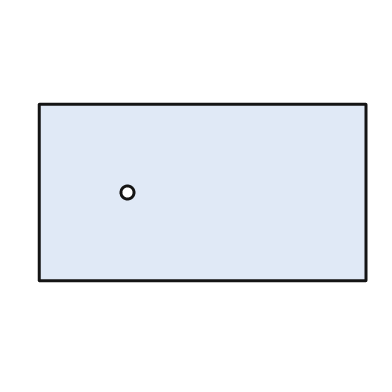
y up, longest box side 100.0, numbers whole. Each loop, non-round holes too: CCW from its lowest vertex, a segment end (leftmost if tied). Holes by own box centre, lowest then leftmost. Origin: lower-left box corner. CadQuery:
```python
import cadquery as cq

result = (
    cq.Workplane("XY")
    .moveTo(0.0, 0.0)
    .lineTo(100.0, 0.0)
    .lineTo(100.0, 54.0)
    .lineTo(0.0, 54.0)
    .close()
    .moveTo(27.0, 27.0)
    .circle(2.0)
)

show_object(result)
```